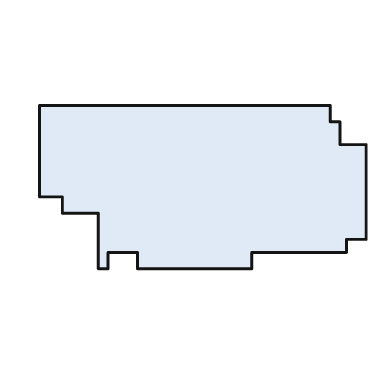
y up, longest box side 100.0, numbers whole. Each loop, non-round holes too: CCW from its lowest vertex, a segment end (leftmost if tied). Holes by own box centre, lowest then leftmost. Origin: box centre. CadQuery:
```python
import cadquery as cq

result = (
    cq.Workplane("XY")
    .moveTo(-32.0, -25.0)
    .lineTo(-29.0, -25.0)
    .lineTo(-29.0, -20.0)
    .lineTo(-20.0, -20.0)
    .lineTo(-20.0, -25.0)
    .lineTo(15.0, -25.0)
    .lineTo(15.0, -20.0)
    .lineTo(44.0, -20.0)
    .lineTo(44.0, -16.0)
    .lineTo(50.0, -16.0)
    .lineTo(50.0, 13.0)
    .lineTo(42.0, 13.0)
    .lineTo(42.0, 20.0)
    .lineTo(39.0, 20.0)
    .lineTo(39.0, 25.0)
    .lineTo(-50.0, 25.0)
    .lineTo(-50.0, -3.0)
    .lineTo(-43.0, -3.0)
    .lineTo(-43.0, -8.0)
    .lineTo(-32.0, -8.0)
    .close()
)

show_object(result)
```